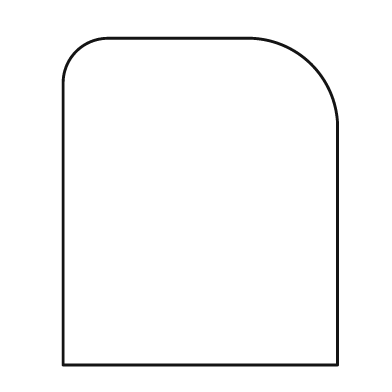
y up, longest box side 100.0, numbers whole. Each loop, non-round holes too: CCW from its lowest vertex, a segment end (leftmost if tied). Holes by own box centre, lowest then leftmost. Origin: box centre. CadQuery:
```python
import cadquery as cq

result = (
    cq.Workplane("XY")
    .moveTo(-42.0, -50.0)
    .lineTo(42.0, -50.0)
    .lineTo(42.0, 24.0)
    .threePointArc((34.0, 42.0), (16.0, 50.0))
    .lineTo(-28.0, 50.0)
    .threePointArc((-38.0, 46.0), (-42.0, 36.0))
    .close()
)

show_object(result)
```